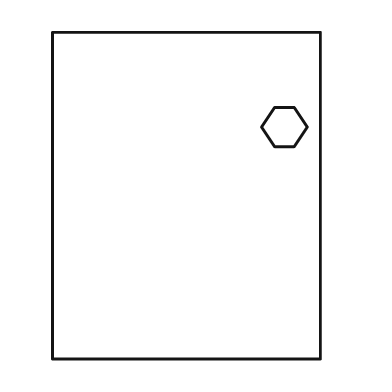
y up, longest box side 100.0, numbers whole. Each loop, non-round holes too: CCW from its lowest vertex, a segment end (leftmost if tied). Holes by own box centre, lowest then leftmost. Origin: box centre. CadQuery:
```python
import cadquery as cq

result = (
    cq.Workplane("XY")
    .moveTo(-41.0, -50.0)
    .lineTo(41.0, -50.0)
    .lineTo(41.0, 50.0)
    .lineTo(-41.0, 50.0)
    .close()
    .moveTo(27.0, 15.0)
    .lineTo(33.0, 15.0)
    .lineTo(37.0, 21.0)
    .lineTo(33.0, 27.0)
    .lineTo(27.0, 27.0)
    .lineTo(23.0, 21.0)
    .close()
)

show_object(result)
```